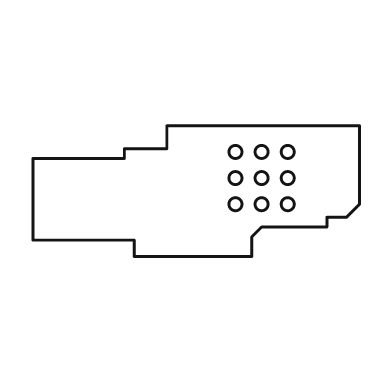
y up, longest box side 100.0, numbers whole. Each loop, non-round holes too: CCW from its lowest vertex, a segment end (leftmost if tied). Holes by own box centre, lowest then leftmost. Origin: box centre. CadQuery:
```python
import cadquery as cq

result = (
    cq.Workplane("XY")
    .moveTo(-19.0, -20.0)
    .lineTo(17.0, -20.0)
    .lineTo(17.0, -14.0)
    .lineTo(20.0, -11.0)
    .lineTo(40.0, -11.0)
    .lineTo(40.0, -8.0)
    .lineTo(46.0, -8.0)
    .lineTo(50.0, -4.0)
    .lineTo(50.0, 20.0)
    .lineTo(-9.0, 20.0)
    .lineTo(-9.0, 13.0)
    .lineTo(-22.0, 13.0)
    .lineTo(-22.0, 10.0)
    .lineTo(-50.0, 10.0)
    .lineTo(-50.0, -15.0)
    .lineTo(-19.0, -15.0)
    .close()
    .moveTo(12.0, -4.0)
    .circle(2.0)
    .moveTo(20.0, -4.0)
    .circle(2.0)
    .moveTo(28.0, -4.0)
    .circle(2.0)
    .moveTo(12.0, 4.0)
    .circle(2.0)
    .moveTo(20.0, 4.0)
    .circle(2.0)
    .moveTo(28.0, 4.0)
    .circle(2.0)
    .moveTo(12.0, 12.0)
    .circle(2.0)
    .moveTo(20.0, 12.0)
    .circle(2.0)
    .moveTo(28.0, 12.0)
    .circle(2.0)
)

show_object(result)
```